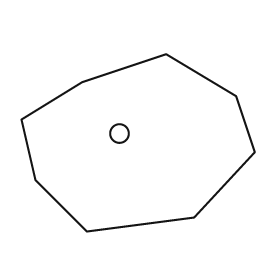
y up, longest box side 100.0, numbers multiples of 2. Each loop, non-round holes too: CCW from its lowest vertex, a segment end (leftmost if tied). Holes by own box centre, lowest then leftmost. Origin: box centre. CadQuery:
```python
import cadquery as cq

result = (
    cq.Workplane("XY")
    .moveTo(-22.0, -38.0)
    .lineTo(24.0, -32.0)
    .lineTo(50.0, -4.0)
    .lineTo(42.0, 20.0)
    .lineTo(12.0, 38.0)
    .lineTo(-24.0, 26.0)
    .lineTo(-50.0, 10.0)
    .lineTo(-44.0, -16.0)
    .close()
    .moveTo(-8.0, 4.0)
    .circle(4.0)
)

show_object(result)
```